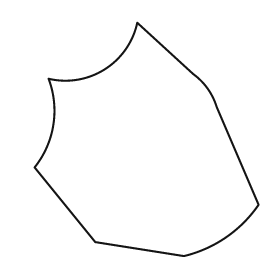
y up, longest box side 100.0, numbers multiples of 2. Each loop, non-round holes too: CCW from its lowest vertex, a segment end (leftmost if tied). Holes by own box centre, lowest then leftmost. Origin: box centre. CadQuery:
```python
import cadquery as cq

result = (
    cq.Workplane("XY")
    .moveTo(16.0, -50.0)
    .threePointArc((34.0, -42.0), (48.0, -28.0))
    .lineTo(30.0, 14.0)
    .threePointArc((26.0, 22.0), (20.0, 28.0))
    .lineTo(-4.0, 50.0)
    .threePointArc((-18.0, 30.0), (-42.0, 26.0))
    .threePointArc((-40.0, 6.0), (-48.0, -12.0))
    .lineTo(-22.0, -44.0)
    .close()
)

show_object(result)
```